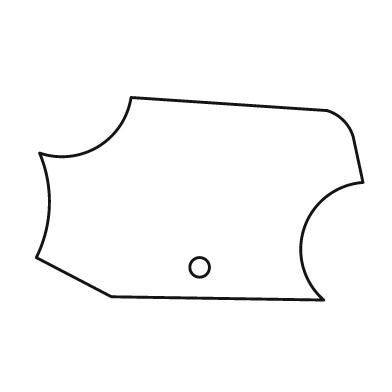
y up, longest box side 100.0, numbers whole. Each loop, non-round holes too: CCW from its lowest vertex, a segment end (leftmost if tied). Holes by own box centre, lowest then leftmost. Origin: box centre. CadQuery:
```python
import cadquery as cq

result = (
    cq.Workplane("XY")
    .moveTo(38.0, -31.0)
    .threePointArc((32.0, -9.0), (50.0, 5.0))
    .lineTo(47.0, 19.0)
    .threePointArc((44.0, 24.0), (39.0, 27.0))
    .lineTo(-21.0, 31.0)
    .threePointArc((-31.0, 16.0), (-49.0, 14.0))
    .threePointArc((-46.0, -2.0), (-50.0, -18.0))
    .lineTo(-27.0, -30.0)
    .close()
    .moveTo(0.0, -21.0)
    .circle(3.0)
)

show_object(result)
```